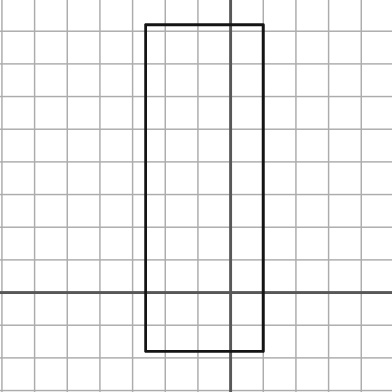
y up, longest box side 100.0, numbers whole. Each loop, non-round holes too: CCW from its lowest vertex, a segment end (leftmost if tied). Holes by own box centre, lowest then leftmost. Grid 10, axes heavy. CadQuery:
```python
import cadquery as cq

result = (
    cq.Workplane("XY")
    .moveTo(-26.0, -18.0)
    .lineTo(10.0, -18.0)
    .lineTo(10.0, 82.0)
    .lineTo(-26.0, 82.0)
    .close()
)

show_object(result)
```